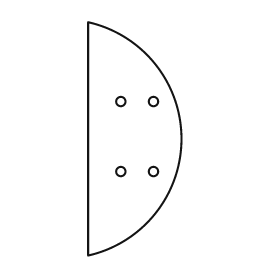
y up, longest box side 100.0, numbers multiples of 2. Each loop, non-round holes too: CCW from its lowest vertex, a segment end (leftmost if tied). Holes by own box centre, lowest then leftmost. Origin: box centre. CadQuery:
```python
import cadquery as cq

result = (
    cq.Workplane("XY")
    .moveTo(-20.0, -50.0)
    .threePointArc((20.0, 0.0), (-20.0, 50.0))
    .close()
    .moveTo(-6.0, -14.0)
    .circle(2.0)
    .moveTo(8.0, -14.0)
    .circle(2.0)
    .moveTo(-6.0, 16.0)
    .circle(2.0)
    .moveTo(8.0, 16.0)
    .circle(2.0)
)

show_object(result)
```